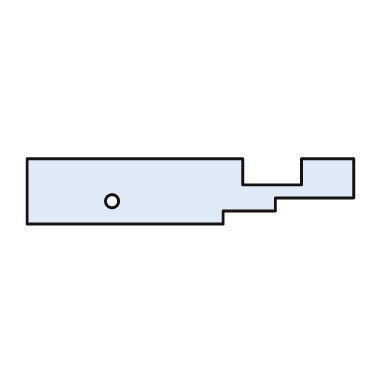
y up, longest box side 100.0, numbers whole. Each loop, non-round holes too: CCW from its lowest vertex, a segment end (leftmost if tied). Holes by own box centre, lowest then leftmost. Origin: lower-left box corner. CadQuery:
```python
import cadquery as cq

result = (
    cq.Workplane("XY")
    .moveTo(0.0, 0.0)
    .lineTo(60.0, 0.0)
    .lineTo(60.0, 4.0)
    .lineTo(76.0, 4.0)
    .lineTo(76.0, 8.0)
    .lineTo(100.0, 8.0)
    .lineTo(100.0, 20.0)
    .lineTo(84.0, 20.0)
    .lineTo(84.0, 12.0)
    .lineTo(66.0, 12.0)
    .lineTo(66.0, 20.0)
    .lineTo(0.0, 20.0)
    .close()
    .moveTo(26.0, 7.0)
    .circle(2.0)
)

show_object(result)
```